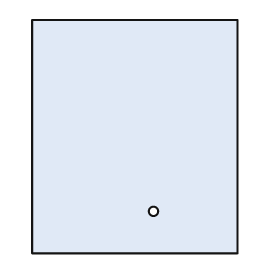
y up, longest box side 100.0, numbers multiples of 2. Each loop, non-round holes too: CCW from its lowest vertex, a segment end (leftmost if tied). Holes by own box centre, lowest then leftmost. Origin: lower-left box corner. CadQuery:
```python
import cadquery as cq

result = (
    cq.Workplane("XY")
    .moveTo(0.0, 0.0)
    .lineTo(88.0, 0.0)
    .lineTo(88.0, 100.0)
    .lineTo(0.0, 100.0)
    .close()
    .moveTo(52.0, 18.0)
    .circle(2.0)
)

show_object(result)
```